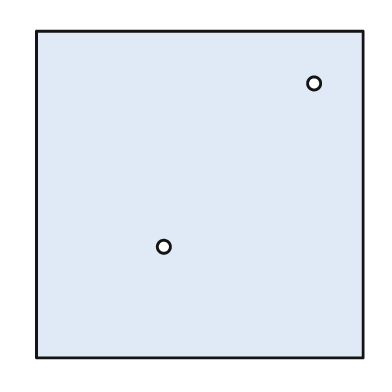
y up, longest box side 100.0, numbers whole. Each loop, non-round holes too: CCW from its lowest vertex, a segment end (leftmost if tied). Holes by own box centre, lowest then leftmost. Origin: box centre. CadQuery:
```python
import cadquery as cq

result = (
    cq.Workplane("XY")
    .moveTo(-50.0, -50.0)
    .lineTo(50.0, -50.0)
    .lineTo(50.0, 50.0)
    .lineTo(-50.0, 50.0)
    .close()
    .moveTo(-11.0, -16.0)
    .circle(2.0)
    .moveTo(35.0, 34.0)
    .circle(2.0)
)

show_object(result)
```